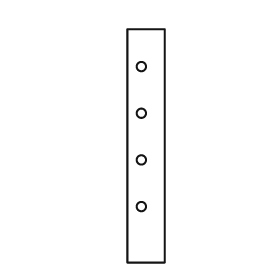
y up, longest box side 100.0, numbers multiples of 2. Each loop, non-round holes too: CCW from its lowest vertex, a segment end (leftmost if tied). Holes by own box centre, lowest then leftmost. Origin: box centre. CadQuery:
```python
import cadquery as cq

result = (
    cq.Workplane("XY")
    .moveTo(-8.0, -50.0)
    .lineTo(8.0, -50.0)
    .lineTo(8.0, 50.0)
    .lineTo(-8.0, 50.0)
    .close()
    .moveTo(-2.0, -26.0)
    .circle(2.0)
    .moveTo(-2.0, -6.0)
    .circle(2.0)
    .moveTo(-2.0, 14.0)
    .circle(2.0)
    .moveTo(-2.0, 34.0)
    .circle(2.0)
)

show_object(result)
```